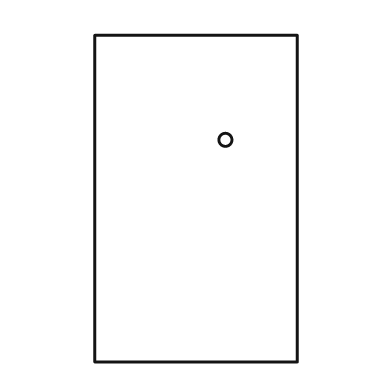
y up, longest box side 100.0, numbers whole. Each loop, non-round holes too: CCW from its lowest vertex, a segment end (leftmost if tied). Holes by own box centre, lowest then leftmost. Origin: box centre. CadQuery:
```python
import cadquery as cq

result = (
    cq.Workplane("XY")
    .moveTo(-31.0, -50.0)
    .lineTo(31.0, -50.0)
    .lineTo(31.0, 50.0)
    .lineTo(-31.0, 50.0)
    .close()
    .moveTo(9.0, 18.0)
    .circle(2.0)
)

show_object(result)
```